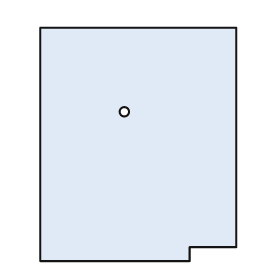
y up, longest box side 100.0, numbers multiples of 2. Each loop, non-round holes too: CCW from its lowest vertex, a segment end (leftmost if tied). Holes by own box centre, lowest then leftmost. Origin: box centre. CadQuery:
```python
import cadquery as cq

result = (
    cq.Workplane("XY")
    .moveTo(-42.0, -50.0)
    .lineTo(22.0, -50.0)
    .lineTo(22.0, -44.0)
    .lineTo(42.0, -44.0)
    .lineTo(42.0, 50.0)
    .lineTo(-42.0, 50.0)
    .close()
    .moveTo(-6.0, 14.0)
    .circle(2.0)
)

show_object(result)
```